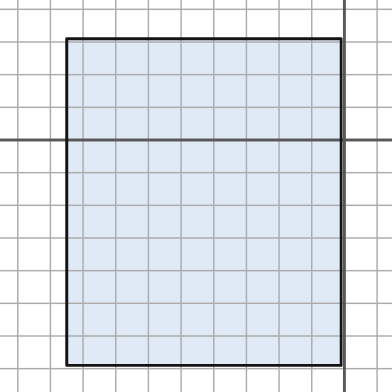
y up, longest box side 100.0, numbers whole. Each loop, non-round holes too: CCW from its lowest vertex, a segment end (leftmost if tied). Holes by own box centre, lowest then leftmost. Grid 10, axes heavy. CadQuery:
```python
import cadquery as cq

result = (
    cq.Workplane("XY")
    .moveTo(-85.0, -69.0)
    .lineTo(-1.0, -69.0)
    .lineTo(-1.0, 31.0)
    .lineTo(-85.0, 31.0)
    .close()
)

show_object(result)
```